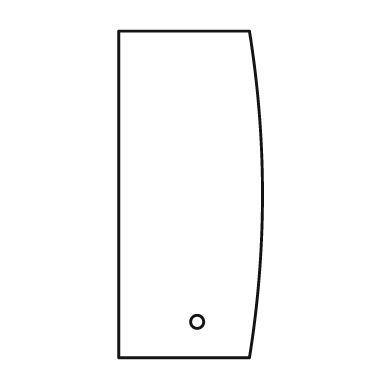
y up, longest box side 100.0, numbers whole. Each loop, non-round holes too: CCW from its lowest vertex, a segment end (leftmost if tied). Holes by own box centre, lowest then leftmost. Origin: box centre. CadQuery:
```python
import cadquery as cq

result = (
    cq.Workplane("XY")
    .moveTo(-22.0, -50.0)
    .lineTo(18.0, -50.0)
    .threePointArc((22.0, 0.0), (18.0, 50.0))
    .lineTo(-22.0, 50.0)
    .close()
    .moveTo(2.0, -39.0)
    .circle(2.0)
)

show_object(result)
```